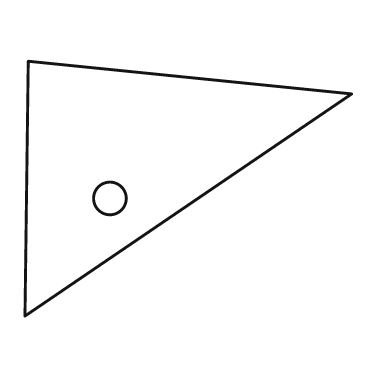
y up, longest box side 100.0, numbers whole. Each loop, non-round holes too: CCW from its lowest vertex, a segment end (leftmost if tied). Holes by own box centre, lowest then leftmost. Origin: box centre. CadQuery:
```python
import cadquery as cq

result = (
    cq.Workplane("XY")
    .moveTo(-50.0, -39.0)
    .lineTo(50.0, 29.0)
    .lineTo(-49.0, 39.0)
    .close()
    .moveTo(-24.0, -3.0)
    .circle(5.0)
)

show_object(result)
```